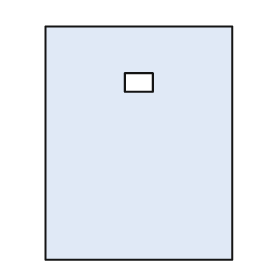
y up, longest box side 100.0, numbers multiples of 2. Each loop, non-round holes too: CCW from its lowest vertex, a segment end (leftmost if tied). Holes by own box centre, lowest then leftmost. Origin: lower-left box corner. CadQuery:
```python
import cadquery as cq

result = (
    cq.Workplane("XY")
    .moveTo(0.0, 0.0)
    .lineTo(80.0, 0.0)
    .lineTo(80.0, 100.0)
    .lineTo(0.0, 100.0)
    .close()
    .moveTo(34.0, 72.0)
    .lineTo(46.0, 72.0)
    .lineTo(46.0, 80.0)
    .lineTo(34.0, 80.0)
    .close()
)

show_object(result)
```